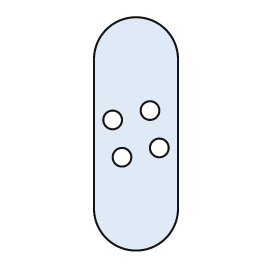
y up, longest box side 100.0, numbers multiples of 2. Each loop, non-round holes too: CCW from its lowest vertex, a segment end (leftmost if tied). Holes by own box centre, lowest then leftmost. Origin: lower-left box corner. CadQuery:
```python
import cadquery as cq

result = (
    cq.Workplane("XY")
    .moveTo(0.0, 18.0)
    .threePointArc((18.0, 0.0), (36.0, 18.0))
    .lineTo(36.0, 82.0)
    .threePointArc((18.0, 100.0), (0.0, 82.0))
    .close()
    .moveTo(12.0, 40.0)
    .circle(4.0)
    .moveTo(28.0, 44.0)
    .circle(4.0)
    .moveTo(8.0, 56.0)
    .circle(4.0)
    .moveTo(24.0, 60.0)
    .circle(4.0)
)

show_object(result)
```